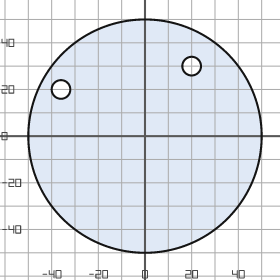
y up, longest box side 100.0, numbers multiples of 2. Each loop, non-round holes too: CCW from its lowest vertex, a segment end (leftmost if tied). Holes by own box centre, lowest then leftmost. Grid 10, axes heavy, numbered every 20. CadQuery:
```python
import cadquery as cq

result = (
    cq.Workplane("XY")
    .moveTo(0.0, 0.0)
    .circle(50.0)
    .moveTo(-36.0, 20.0)
    .circle(4.0)
    .moveTo(20.0, 30.0)
    .circle(4.0)
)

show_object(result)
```